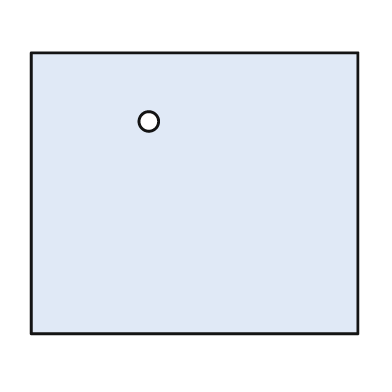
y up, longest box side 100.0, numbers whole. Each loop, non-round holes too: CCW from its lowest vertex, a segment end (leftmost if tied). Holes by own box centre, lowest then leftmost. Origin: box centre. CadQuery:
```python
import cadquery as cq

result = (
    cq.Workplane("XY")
    .moveTo(-50.0, -43.0)
    .lineTo(50.0, -43.0)
    .lineTo(50.0, 43.0)
    .lineTo(-50.0, 43.0)
    .close()
    .moveTo(-14.0, 22.0)
    .circle(3.0)
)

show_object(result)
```